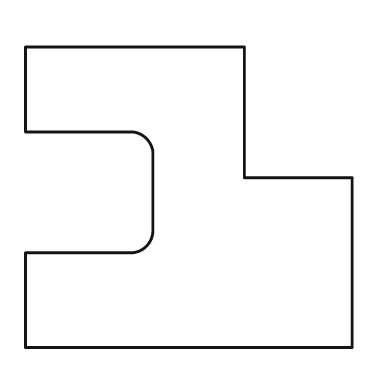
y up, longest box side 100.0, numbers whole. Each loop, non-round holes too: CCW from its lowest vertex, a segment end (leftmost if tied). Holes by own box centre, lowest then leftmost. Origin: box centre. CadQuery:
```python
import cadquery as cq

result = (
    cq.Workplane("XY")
    .moveTo(-50.0, -46.0)
    .lineTo(50.0, -46.0)
    .lineTo(50.0, 6.0)
    .lineTo(17.0, 6.0)
    .lineTo(17.0, 46.0)
    .lineTo(-50.0, 46.0)
    .lineTo(-50.0, 20.0)
    .lineTo(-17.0, 20.0)
    .threePointArc((-13.0, 18.0), (-11.0, 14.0))
    .lineTo(-11.0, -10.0)
    .threePointArc((-13.0, -15.0), (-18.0, -17.0))
    .lineTo(-50.0, -17.0)
    .close()
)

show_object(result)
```